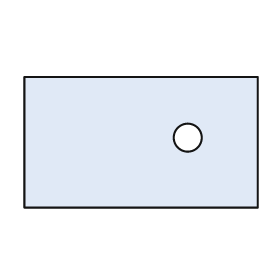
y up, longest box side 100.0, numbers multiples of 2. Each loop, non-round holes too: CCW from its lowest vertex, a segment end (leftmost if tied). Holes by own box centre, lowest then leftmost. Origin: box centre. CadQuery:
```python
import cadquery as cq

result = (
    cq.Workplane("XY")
    .moveTo(-50.0, -28.0)
    .lineTo(50.0, -28.0)
    .lineTo(50.0, 28.0)
    .lineTo(-50.0, 28.0)
    .close()
    .moveTo(20.0, 2.0)
    .circle(6.0)
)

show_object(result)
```